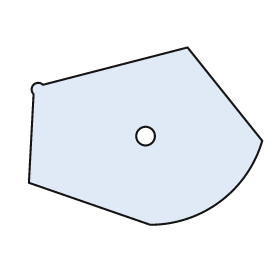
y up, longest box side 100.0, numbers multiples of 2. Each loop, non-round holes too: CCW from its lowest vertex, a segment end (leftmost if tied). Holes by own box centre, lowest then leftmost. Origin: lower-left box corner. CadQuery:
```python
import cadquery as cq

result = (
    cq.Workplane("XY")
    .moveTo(52.0, 0.0)
    .threePointArc((82.0, 10.0), (100.0, 36.0))
    .lineTo(68.0, 76.0)
    .lineTo(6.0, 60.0)
    .threePointArc((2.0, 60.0), (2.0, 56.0))
    .lineTo(0.0, 18.0)
    .close()
    .moveTo(50.0, 38.0)
    .circle(4.0)
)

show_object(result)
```